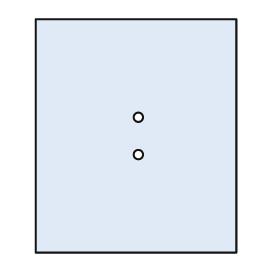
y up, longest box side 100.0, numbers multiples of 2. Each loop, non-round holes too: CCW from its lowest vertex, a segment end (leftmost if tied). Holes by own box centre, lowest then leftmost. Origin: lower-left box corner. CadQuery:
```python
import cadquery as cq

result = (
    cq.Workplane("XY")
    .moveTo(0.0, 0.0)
    .lineTo(86.0, 0.0)
    .lineTo(86.0, 100.0)
    .lineTo(0.0, 100.0)
    .close()
    .moveTo(44.0, 42.0)
    .circle(2.0)
    .moveTo(44.0, 58.0)
    .circle(2.0)
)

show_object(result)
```